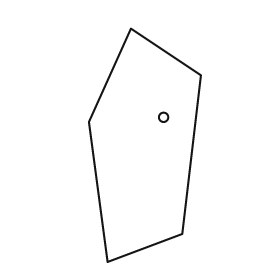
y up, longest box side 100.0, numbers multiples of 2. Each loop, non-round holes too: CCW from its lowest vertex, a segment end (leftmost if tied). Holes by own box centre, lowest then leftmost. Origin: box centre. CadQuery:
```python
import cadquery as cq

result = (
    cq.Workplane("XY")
    .moveTo(-16.0, -50.0)
    .lineTo(16.0, -38.0)
    .lineTo(24.0, 30.0)
    .lineTo(-6.0, 50.0)
    .lineTo(-24.0, 10.0)
    .close()
    .moveTo(8.0, 12.0)
    .circle(2.0)
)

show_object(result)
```